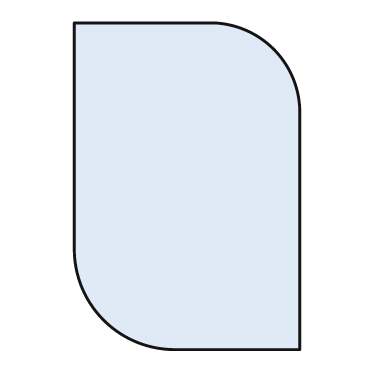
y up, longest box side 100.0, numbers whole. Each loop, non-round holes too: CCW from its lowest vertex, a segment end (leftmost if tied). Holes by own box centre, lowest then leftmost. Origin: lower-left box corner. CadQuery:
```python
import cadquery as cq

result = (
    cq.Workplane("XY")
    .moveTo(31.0, 0.0)
    .lineTo(69.0, 0.0)
    .lineTo(69.0, 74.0)
    .threePointArc((61.0, 92.0), (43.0, 100.0))
    .lineTo(0.0, 100.0)
    .lineTo(0.0, 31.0)
    .threePointArc((9.0, 9.0), (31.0, 0.0))
    .close()
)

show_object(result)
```